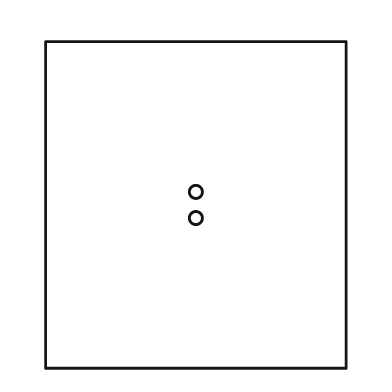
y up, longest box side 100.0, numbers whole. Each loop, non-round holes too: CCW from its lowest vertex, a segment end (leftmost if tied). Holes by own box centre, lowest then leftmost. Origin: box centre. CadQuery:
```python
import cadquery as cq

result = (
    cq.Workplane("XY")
    .moveTo(-46.0, -50.0)
    .lineTo(46.0, -50.0)
    .lineTo(46.0, 50.0)
    .lineTo(-46.0, 50.0)
    .close()
    .moveTo(0.0, -4.0)
    .circle(2.0)
    .moveTo(0.0, 4.0)
    .circle(2.0)
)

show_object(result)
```